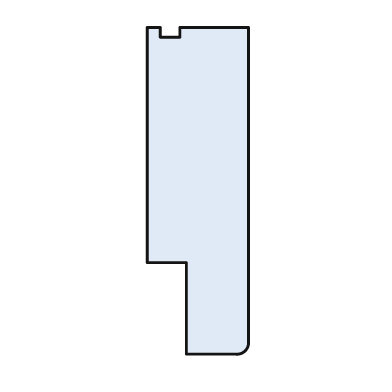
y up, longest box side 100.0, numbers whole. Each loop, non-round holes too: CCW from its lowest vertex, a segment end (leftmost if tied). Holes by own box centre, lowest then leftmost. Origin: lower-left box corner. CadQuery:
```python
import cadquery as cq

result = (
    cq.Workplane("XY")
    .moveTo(12.0, 0.0)
    .lineTo(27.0, 0.0)
    .threePointArc((30.0, 1.0), (31.0, 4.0))
    .lineTo(31.0, 100.0)
    .lineTo(10.0, 100.0)
    .lineTo(10.0, 97.0)
    .lineTo(4.0, 97.0)
    .lineTo(4.0, 100.0)
    .lineTo(0.0, 100.0)
    .lineTo(0.0, 28.0)
    .lineTo(12.0, 28.0)
    .close()
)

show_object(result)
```